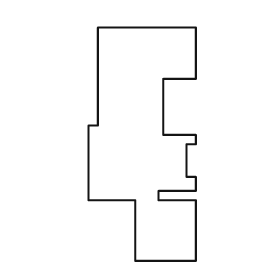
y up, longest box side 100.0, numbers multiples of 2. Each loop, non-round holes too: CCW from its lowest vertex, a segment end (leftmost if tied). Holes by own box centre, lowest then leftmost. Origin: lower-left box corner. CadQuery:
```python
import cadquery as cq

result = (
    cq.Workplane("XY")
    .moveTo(20.0, 0.0)
    .lineTo(46.0, 0.0)
    .lineTo(46.0, 26.0)
    .lineTo(30.0, 26.0)
    .lineTo(30.0, 30.0)
    .lineTo(46.0, 30.0)
    .lineTo(46.0, 36.0)
    .lineTo(42.0, 36.0)
    .lineTo(42.0, 50.0)
    .lineTo(46.0, 50.0)
    .lineTo(46.0, 54.0)
    .lineTo(32.0, 54.0)
    .lineTo(32.0, 78.0)
    .lineTo(46.0, 78.0)
    .lineTo(46.0, 100.0)
    .lineTo(4.0, 100.0)
    .lineTo(4.0, 58.0)
    .lineTo(0.0, 58.0)
    .lineTo(0.0, 26.0)
    .lineTo(20.0, 26.0)
    .close()
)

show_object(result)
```